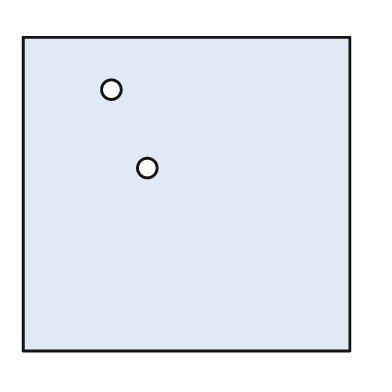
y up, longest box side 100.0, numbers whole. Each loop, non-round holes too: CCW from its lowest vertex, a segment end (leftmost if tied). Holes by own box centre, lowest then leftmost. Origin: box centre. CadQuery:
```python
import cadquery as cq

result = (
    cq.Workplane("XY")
    .moveTo(-50.0, -48.0)
    .lineTo(50.0, -48.0)
    .lineTo(50.0, 48.0)
    .lineTo(-50.0, 48.0)
    .close()
    .moveTo(-12.0, 8.0)
    .circle(3.0)
    .moveTo(-23.0, 32.0)
    .circle(3.0)
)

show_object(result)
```